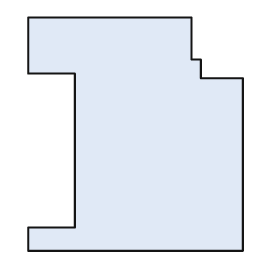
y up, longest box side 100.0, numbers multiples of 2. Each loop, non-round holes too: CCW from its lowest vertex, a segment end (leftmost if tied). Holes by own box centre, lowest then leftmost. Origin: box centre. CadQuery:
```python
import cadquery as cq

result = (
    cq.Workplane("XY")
    .moveTo(-46.0, -50.0)
    .lineTo(46.0, -50.0)
    .lineTo(46.0, 24.0)
    .lineTo(28.0, 24.0)
    .lineTo(28.0, 32.0)
    .lineTo(24.0, 32.0)
    .lineTo(24.0, 50.0)
    .lineTo(-46.0, 50.0)
    .lineTo(-46.0, 26.0)
    .lineTo(-26.0, 26.0)
    .lineTo(-26.0, -40.0)
    .lineTo(-46.0, -40.0)
    .close()
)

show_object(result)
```